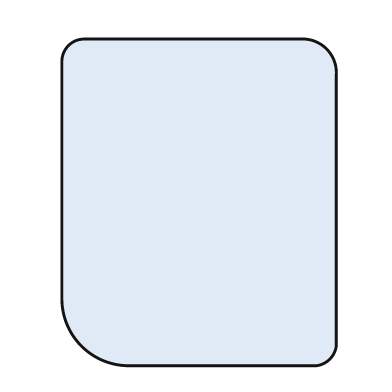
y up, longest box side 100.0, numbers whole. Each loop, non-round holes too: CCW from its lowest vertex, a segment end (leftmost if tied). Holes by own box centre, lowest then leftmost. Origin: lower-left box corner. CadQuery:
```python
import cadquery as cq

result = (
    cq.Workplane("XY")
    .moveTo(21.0, 0.0)
    .lineTo(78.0, 0.0)
    .threePointArc((82.0, 2.0), (84.0, 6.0))
    .lineTo(84.0, 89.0)
    .threePointArc((81.0, 97.0), (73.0, 100.0))
    .lineTo(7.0, 100.0)
    .threePointArc((2.0, 98.0), (0.0, 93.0))
    .lineTo(0.0, 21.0)
    .threePointArc((6.0, 6.0), (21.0, 0.0))
    .close()
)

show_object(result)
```